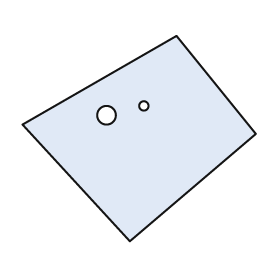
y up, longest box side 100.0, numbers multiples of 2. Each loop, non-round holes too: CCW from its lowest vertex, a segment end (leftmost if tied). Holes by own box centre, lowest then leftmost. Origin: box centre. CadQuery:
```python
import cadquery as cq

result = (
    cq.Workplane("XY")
    .moveTo(-4.0, -44.0)
    .lineTo(50.0, 2.0)
    .lineTo(16.0, 44.0)
    .lineTo(-50.0, 6.0)
    .close()
    .moveTo(-14.0, 10.0)
    .circle(4.0)
    .moveTo(2.0, 14.0)
    .circle(2.0)
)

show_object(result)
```